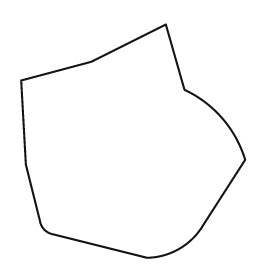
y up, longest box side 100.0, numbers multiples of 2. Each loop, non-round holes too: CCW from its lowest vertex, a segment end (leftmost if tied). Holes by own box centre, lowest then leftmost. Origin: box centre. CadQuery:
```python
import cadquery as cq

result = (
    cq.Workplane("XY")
    .moveTo(6.0, -50.0)
    .threePointArc((20.0, -46.0), (30.0, -36.0))
    .lineTo(48.0, -8.0)
    .threePointArc((38.0, 10.0), (22.0, 22.0))
    .lineTo(14.0, 50.0)
    .lineTo(-18.0, 34.0)
    .lineTo(-48.0, 26.0)
    .lineTo(-46.0, -10.0)
    .lineTo(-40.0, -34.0)
    .threePointArc((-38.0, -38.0), (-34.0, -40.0))
    .close()
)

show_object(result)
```